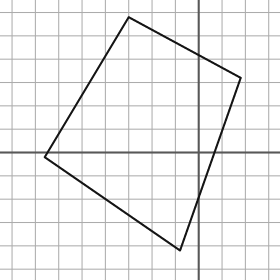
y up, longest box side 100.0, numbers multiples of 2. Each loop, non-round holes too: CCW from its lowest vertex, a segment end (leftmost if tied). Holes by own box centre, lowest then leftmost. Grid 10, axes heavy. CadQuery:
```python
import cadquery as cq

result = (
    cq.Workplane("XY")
    .moveTo(-8.0, -42.0)
    .lineTo(18.0, 32.0)
    .lineTo(-30.0, 58.0)
    .lineTo(-66.0, -2.0)
    .close()
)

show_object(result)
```